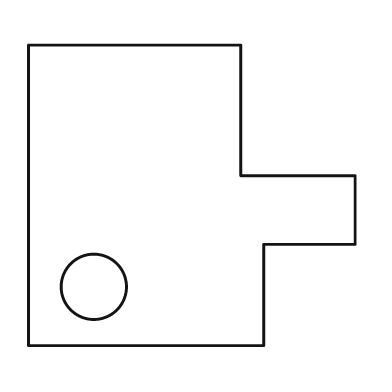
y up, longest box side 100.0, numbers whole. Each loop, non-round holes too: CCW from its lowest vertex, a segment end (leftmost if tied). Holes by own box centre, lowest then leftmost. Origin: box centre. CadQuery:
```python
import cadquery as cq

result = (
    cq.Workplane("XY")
    .moveTo(-50.0, -46.0)
    .lineTo(22.0, -46.0)
    .lineTo(22.0, -15.0)
    .lineTo(50.0, -15.0)
    .lineTo(50.0, 6.0)
    .lineTo(15.0, 6.0)
    .lineTo(15.0, 46.0)
    .lineTo(-50.0, 46.0)
    .close()
    .moveTo(-30.0, -28.0)
    .circle(10.0)
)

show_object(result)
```